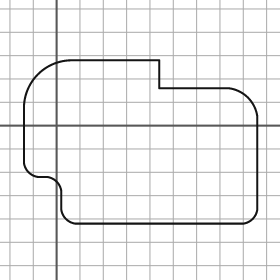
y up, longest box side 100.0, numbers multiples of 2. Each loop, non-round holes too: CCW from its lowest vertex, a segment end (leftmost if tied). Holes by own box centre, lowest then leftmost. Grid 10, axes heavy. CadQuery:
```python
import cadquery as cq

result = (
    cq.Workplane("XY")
    .moveTo(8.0, -42.0)
    .lineTo(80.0, -42.0)
    .threePointArc((84.0, -40.0), (86.0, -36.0))
    .lineTo(86.0, 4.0)
    .threePointArc((82.0, 12.0), (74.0, 16.0))
    .lineTo(44.0, 16.0)
    .lineTo(44.0, 28.0)
    .lineTo(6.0, 28.0)
    .threePointArc((-8.0, 22.0), (-14.0, 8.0))
    .lineTo(-14.0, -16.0)
    .threePointArc((-12.0, -20.0), (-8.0, -22.0))
    .lineTo(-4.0, -22.0)
    .threePointArc((0.0, -24.0), (2.0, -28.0))
    .lineTo(2.0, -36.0)
    .threePointArc((4.0, -40.0), (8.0, -42.0))
    .close()
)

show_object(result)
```